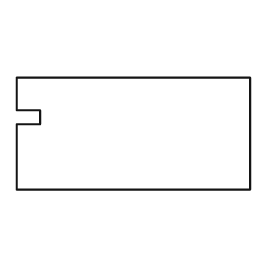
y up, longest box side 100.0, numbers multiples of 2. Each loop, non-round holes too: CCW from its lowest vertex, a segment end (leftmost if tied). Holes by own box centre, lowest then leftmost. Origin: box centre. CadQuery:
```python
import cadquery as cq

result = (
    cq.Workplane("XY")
    .moveTo(-50.0, -24.0)
    .lineTo(50.0, -24.0)
    .lineTo(50.0, 24.0)
    .lineTo(-50.0, 24.0)
    .lineTo(-50.0, 10.0)
    .lineTo(-40.0, 10.0)
    .lineTo(-40.0, 4.0)
    .lineTo(-50.0, 4.0)
    .close()
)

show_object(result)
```